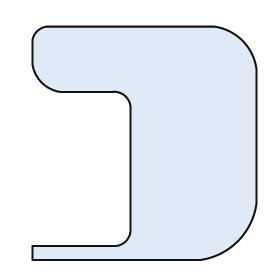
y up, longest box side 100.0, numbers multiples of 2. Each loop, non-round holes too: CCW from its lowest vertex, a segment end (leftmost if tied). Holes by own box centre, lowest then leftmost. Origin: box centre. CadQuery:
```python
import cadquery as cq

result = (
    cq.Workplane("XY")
    .moveTo(-48.0, -50.0)
    .lineTo(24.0, -50.0)
    .threePointArc((40.0, -42.0), (48.0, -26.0))
    .lineTo(48.0, 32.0)
    .threePointArc((42.0, 44.0), (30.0, 50.0))
    .lineTo(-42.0, 50.0)
    .threePointArc((-46.0, 48.0), (-48.0, 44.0))
    .lineTo(-48.0, 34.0)
    .threePointArc((-44.0, 26.0), (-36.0, 22.0))
    .lineTo(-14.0, 22.0)
    .threePointArc((-8.0, 20.0), (-6.0, 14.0))
    .lineTo(-6.0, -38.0)
    .threePointArc((-8.0, -42.0), (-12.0, -44.0))
    .lineTo(-48.0, -44.0)
    .close()
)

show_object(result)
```